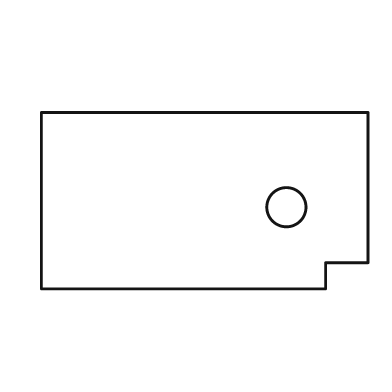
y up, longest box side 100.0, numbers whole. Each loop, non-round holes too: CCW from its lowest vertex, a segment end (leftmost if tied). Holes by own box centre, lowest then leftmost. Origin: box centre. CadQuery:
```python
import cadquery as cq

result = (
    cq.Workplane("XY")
    .moveTo(-50.0, -27.0)
    .lineTo(37.0, -27.0)
    .lineTo(37.0, -19.0)
    .lineTo(50.0, -19.0)
    .lineTo(50.0, 27.0)
    .lineTo(-50.0, 27.0)
    .close()
    .moveTo(25.0, -2.0)
    .circle(6.0)
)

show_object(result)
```